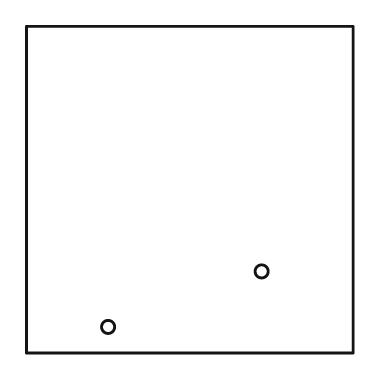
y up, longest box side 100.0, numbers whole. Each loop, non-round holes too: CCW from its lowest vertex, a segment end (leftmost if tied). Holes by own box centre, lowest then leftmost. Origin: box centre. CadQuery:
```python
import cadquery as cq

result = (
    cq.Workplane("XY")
    .moveTo(-50.0, -50.0)
    .lineTo(50.0, -50.0)
    .lineTo(50.0, 50.0)
    .lineTo(-50.0, 50.0)
    .close()
    .moveTo(-25.0, -42.0)
    .circle(2.0)
    .moveTo(22.0, -25.0)
    .circle(2.0)
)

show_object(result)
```